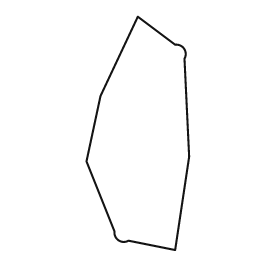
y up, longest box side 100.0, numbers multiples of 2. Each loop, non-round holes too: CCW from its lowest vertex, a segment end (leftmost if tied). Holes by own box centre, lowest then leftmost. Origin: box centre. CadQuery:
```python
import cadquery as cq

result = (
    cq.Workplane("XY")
    .moveTo(16.0, -50.0)
    .lineTo(22.0, -10.0)
    .lineTo(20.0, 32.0)
    .threePointArc((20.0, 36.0), (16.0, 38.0))
    .lineTo(0.0, 50.0)
    .lineTo(-16.0, 16.0)
    .lineTo(-22.0, -12.0)
    .lineTo(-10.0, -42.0)
    .threePointArc((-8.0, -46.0), (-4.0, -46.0))
    .close()
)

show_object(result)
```